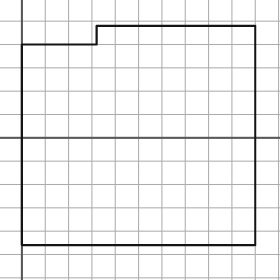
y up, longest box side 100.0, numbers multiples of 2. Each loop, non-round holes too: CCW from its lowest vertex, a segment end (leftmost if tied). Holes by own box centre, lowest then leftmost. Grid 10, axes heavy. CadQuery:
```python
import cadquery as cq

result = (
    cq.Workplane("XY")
    .moveTo(0.0, -46.0)
    .lineTo(100.0, -46.0)
    .lineTo(100.0, 48.0)
    .lineTo(32.0, 48.0)
    .lineTo(32.0, 40.0)
    .lineTo(0.0, 40.0)
    .close()
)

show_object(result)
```